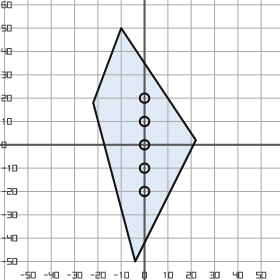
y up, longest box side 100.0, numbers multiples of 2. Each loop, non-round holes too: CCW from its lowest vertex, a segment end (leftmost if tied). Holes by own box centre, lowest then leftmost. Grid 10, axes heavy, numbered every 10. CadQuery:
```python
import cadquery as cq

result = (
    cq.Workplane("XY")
    .moveTo(-4.0, -50.0)
    .lineTo(22.0, 2.0)
    .lineTo(-10.0, 50.0)
    .lineTo(-22.0, 18.0)
    .close()
    .moveTo(0.0, -20.0)
    .circle(2.0)
    .moveTo(0.0, -10.0)
    .circle(2.0)
    .moveTo(0.0, 0.0)
    .circle(2.0)
    .moveTo(0.0, 10.0)
    .circle(2.0)
    .moveTo(0.0, 20.0)
    .circle(2.0)
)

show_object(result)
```